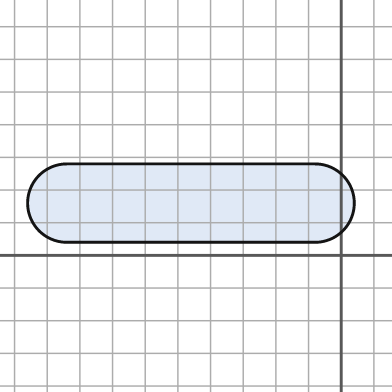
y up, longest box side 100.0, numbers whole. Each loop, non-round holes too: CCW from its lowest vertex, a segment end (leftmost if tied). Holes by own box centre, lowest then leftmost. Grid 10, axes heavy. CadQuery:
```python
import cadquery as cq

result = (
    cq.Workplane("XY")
    .moveTo(-84.0, 4.0)
    .lineTo(-8.0, 4.0)
    .threePointArc((4.0, 16.0), (-8.0, 28.0))
    .lineTo(-84.0, 28.0)
    .threePointArc((-96.0, 16.0), (-84.0, 4.0))
    .close()
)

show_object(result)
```